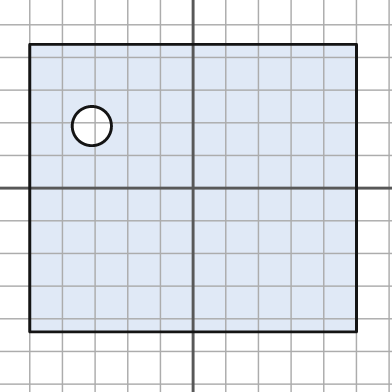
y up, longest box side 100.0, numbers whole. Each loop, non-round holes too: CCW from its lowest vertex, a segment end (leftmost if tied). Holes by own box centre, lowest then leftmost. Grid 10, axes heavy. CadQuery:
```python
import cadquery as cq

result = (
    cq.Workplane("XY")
    .moveTo(-50.0, -44.0)
    .lineTo(50.0, -44.0)
    .lineTo(50.0, 44.0)
    .lineTo(-50.0, 44.0)
    .close()
    .moveTo(-31.0, 19.0)
    .circle(6.0)
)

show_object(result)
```